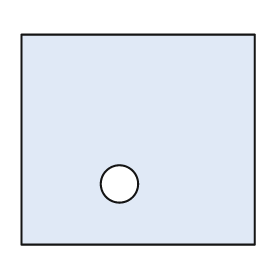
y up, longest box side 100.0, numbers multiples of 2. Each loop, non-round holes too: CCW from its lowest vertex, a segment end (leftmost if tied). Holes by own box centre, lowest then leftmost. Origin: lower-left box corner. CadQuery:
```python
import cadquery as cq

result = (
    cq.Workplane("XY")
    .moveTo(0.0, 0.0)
    .lineTo(100.0, 0.0)
    .lineTo(100.0, 90.0)
    .lineTo(0.0, 90.0)
    .close()
    .moveTo(42.0, 26.0)
    .circle(8.0)
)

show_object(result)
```